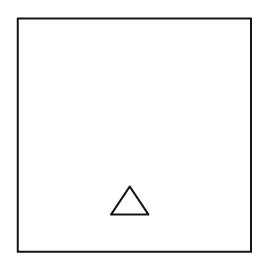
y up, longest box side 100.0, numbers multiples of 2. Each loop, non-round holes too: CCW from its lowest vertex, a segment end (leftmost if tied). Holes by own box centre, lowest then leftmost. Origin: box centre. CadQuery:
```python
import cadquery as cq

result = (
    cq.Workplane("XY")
    .moveTo(-50.0, -50.0)
    .lineTo(50.0, -50.0)
    .lineTo(50.0, 50.0)
    .lineTo(-50.0, 50.0)
    .close()
    .moveTo(-10.0, -34.0)
    .lineTo(6.0, -34.0)
    .lineTo(-2.0, -22.0)
    .close()
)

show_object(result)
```